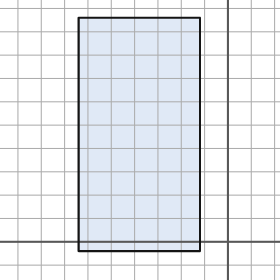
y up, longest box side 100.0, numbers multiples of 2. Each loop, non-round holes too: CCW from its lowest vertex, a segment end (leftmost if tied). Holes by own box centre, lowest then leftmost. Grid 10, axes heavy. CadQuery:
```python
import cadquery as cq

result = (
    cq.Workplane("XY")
    .moveTo(-64.0, -4.0)
    .lineTo(-12.0, -4.0)
    .lineTo(-12.0, 96.0)
    .lineTo(-64.0, 96.0)
    .close()
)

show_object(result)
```